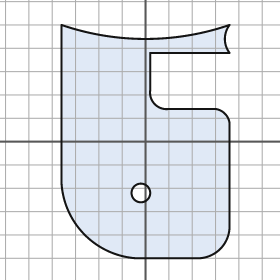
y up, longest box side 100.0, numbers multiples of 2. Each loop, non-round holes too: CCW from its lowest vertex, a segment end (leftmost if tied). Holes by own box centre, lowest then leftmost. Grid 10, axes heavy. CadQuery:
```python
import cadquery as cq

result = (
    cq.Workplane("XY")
    .moveTo(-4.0, -50.0)
    .lineTo(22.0, -50.0)
    .threePointArc((32.0, -46.0), (36.0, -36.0))
    .lineTo(36.0, 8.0)
    .threePointArc((34.0, 12.0), (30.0, 14.0))
    .lineTo(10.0, 14.0)
    .threePointArc((4.0, 16.0), (2.0, 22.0))
    .lineTo(2.0, 38.0)
    .lineTo(36.0, 38.0)
    .threePointArc((34.0, 44.0), (36.0, 50.0))
    .threePointArc((0.0, 44.0), (-36.0, 50.0))
    .lineTo(-36.0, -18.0)
    .threePointArc((-26.0, -40.0), (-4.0, -50.0))
    .close()
    .moveTo(-2.0, -22.0)
    .circle(4.0)
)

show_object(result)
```